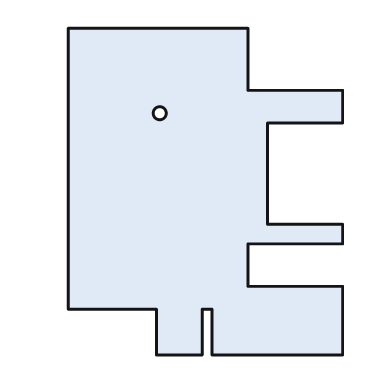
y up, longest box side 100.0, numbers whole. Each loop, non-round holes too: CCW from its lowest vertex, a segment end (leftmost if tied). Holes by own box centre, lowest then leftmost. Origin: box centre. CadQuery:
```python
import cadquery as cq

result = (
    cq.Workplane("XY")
    .moveTo(-15.0, -50.0)
    .lineTo(-1.0, -50.0)
    .lineTo(-1.0, -36.0)
    .lineTo(2.0, -36.0)
    .lineTo(2.0, -50.0)
    .lineTo(42.0, -50.0)
    .lineTo(42.0, -29.0)
    .lineTo(13.0, -29.0)
    .lineTo(13.0, -16.0)
    .lineTo(42.0, -16.0)
    .lineTo(42.0, -10.0)
    .lineTo(19.0, -10.0)
    .lineTo(19.0, 21.0)
    .lineTo(42.0, 21.0)
    .lineTo(42.0, 31.0)
    .lineTo(13.0, 31.0)
    .lineTo(13.0, 50.0)
    .lineTo(-42.0, 50.0)
    .lineTo(-42.0, -36.0)
    .lineTo(-15.0, -36.0)
    .close()
    .moveTo(-14.0, 24.0)
    .circle(2.0)
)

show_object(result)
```